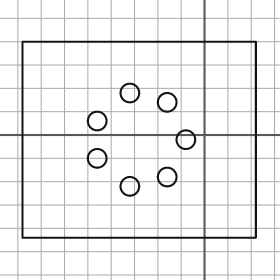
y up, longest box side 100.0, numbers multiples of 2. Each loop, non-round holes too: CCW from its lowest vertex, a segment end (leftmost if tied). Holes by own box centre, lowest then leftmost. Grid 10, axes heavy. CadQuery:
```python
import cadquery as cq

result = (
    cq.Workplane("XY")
    .moveTo(-78.0, -44.0)
    .lineTo(22.0, -44.0)
    .lineTo(22.0, 40.0)
    .lineTo(-78.0, 40.0)
    .close()
    .moveTo(-32.0, -22.0)
    .circle(4.0)
    .moveTo(-16.0, -18.0)
    .circle(4.0)
    .moveTo(-46.0, -10.0)
    .circle(4.0)
    .moveTo(-8.0, -2.0)
    .circle(4.0)
    .moveTo(-46.0, 6.0)
    .circle(4.0)
    .moveTo(-16.0, 14.0)
    .circle(4.0)
    .moveTo(-32.0, 18.0)
    .circle(4.0)
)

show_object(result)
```